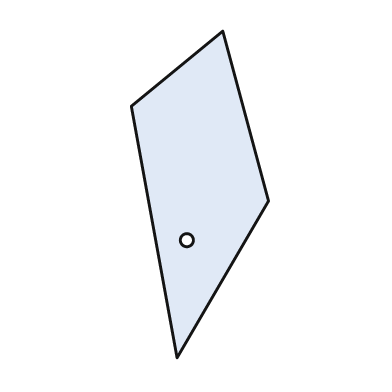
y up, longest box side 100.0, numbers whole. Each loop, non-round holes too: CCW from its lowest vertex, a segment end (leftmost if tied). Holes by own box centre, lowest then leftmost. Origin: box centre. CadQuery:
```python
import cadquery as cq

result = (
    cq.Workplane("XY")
    .moveTo(-7.0, -50.0)
    .lineTo(21.0, -2.0)
    .lineTo(7.0, 50.0)
    .lineTo(-21.0, 27.0)
    .close()
    .moveTo(-4.0, -14.0)
    .circle(2.0)
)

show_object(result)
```